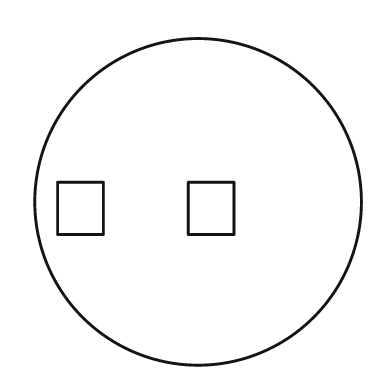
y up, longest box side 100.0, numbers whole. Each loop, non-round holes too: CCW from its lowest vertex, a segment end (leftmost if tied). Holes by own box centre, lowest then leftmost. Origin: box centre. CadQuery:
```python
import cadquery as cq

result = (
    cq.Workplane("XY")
    .moveTo(0.0, 0.0)
    .circle(50.0)
    .moveTo(-43.0, -10.0)
    .lineTo(-29.0, -10.0)
    .lineTo(-29.0, 6.0)
    .lineTo(-43.0, 6.0)
    .close()
    .moveTo(-3.0, -10.0)
    .lineTo(11.0, -10.0)
    .lineTo(11.0, 6.0)
    .lineTo(-3.0, 6.0)
    .close()
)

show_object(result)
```